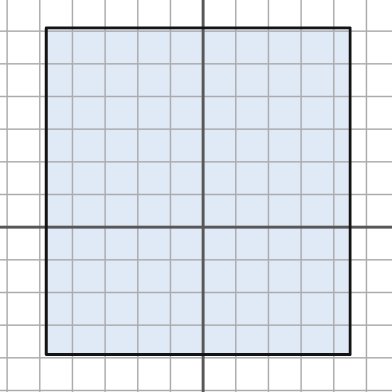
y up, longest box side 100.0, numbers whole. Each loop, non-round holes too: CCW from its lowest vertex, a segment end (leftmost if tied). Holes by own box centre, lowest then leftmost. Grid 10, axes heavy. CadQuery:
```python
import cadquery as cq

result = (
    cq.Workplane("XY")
    .moveTo(-48.0, -39.0)
    .lineTo(45.0, -39.0)
    .lineTo(45.0, 61.0)
    .lineTo(-48.0, 61.0)
    .close()
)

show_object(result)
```